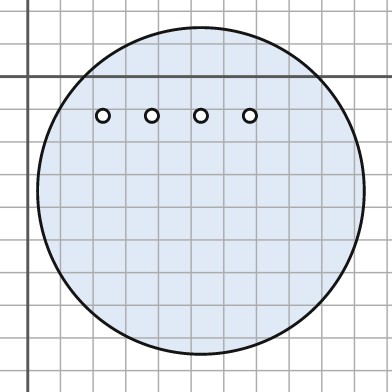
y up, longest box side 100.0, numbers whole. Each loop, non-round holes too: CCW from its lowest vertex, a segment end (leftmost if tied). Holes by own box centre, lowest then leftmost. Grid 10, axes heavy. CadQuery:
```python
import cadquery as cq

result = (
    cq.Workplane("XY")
    .moveTo(53.0, -35.0)
    .circle(50.0)
    .moveTo(23.0, -12.0)
    .circle(2.0)
    .moveTo(38.0, -12.0)
    .circle(2.0)
    .moveTo(53.0, -12.0)
    .circle(2.0)
    .moveTo(68.0, -12.0)
    .circle(2.0)
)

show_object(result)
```